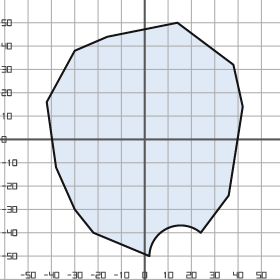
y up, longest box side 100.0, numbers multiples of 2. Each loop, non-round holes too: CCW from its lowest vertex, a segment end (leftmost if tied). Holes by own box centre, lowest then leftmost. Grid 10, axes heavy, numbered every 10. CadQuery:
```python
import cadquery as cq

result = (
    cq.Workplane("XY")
    .moveTo(2.0, -50.0)
    .threePointArc((10.0, -38.0), (24.0, -40.0))
    .lineTo(36.0, -24.0)
    .lineTo(42.0, 14.0)
    .lineTo(38.0, 32.0)
    .lineTo(14.0, 50.0)
    .lineTo(-16.0, 44.0)
    .lineTo(-30.0, 38.0)
    .lineTo(-42.0, 16.0)
    .lineTo(-38.0, -12.0)
    .lineTo(-30.0, -30.0)
    .lineTo(-22.0, -40.0)
    .close()
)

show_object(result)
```